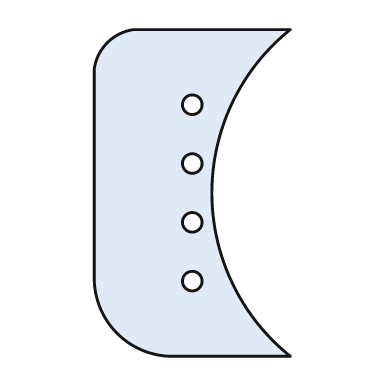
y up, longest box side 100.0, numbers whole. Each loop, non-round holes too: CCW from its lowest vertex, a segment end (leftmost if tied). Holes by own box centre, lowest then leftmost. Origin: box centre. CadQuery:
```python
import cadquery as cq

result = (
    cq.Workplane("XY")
    .moveTo(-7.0, -50.0)
    .lineTo(30.0, -50.0)
    .threePointArc((6.0, 0.0), (30.0, 50.0))
    .lineTo(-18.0, 50.0)
    .threePointArc((-26.0, 46.0), (-30.0, 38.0))
    .lineTo(-30.0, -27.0)
    .threePointArc((-23.0, -43.0), (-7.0, -50.0))
    .close()
    .moveTo(0.0, -27.0)
    .circle(3.0)
    .moveTo(0.0, -9.0)
    .circle(3.0)
    .moveTo(0.0, 9.0)
    .circle(3.0)
    .moveTo(0.0, 27.0)
    .circle(3.0)
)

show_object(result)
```